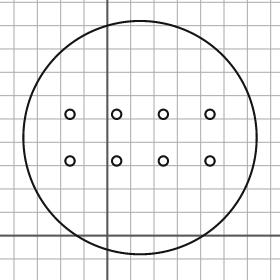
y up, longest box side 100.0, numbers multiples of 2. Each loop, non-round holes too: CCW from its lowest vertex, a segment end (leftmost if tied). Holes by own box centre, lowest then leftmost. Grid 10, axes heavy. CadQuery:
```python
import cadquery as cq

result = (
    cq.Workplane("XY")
    .moveTo(14.0, 42.0)
    .circle(50.0)
    .moveTo(-16.0, 32.0)
    .circle(2.0)
    .moveTo(4.0, 32.0)
    .circle(2.0)
    .moveTo(24.0, 32.0)
    .circle(2.0)
    .moveTo(44.0, 32.0)
    .circle(2.0)
    .moveTo(-16.0, 52.0)
    .circle(2.0)
    .moveTo(4.0, 52.0)
    .circle(2.0)
    .moveTo(24.0, 52.0)
    .circle(2.0)
    .moveTo(44.0, 52.0)
    .circle(2.0)
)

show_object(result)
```